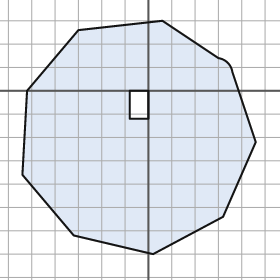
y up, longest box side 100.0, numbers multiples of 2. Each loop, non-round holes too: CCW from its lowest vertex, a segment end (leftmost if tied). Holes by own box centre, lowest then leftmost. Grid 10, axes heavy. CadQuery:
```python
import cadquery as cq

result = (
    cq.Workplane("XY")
    .moveTo(2.0, -70.0)
    .lineTo(32.0, -54.0)
    .lineTo(46.0, -22.0)
    .lineTo(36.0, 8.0)
    .threePointArc((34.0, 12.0), (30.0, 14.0))
    .lineTo(6.0, 30.0)
    .lineTo(-30.0, 26.0)
    .lineTo(-52.0, 0.0)
    .lineTo(-54.0, -36.0)
    .lineTo(-32.0, -62.0)
    .close()
    .moveTo(-8.0, -12.0)
    .lineTo(0.0, -12.0)
    .lineTo(0.0, 0.0)
    .lineTo(-8.0, 0.0)
    .close()
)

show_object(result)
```